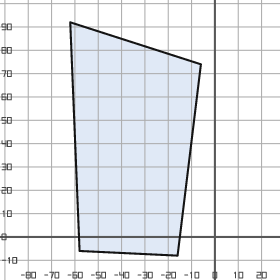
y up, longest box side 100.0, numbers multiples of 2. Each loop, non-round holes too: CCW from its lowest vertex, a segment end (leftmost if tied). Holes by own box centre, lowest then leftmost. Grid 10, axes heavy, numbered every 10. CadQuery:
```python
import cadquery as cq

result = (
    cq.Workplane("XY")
    .moveTo(-16.0, -8.0)
    .lineTo(-6.0, 74.0)
    .lineTo(-62.0, 92.0)
    .lineTo(-58.0, -6.0)
    .close()
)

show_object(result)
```